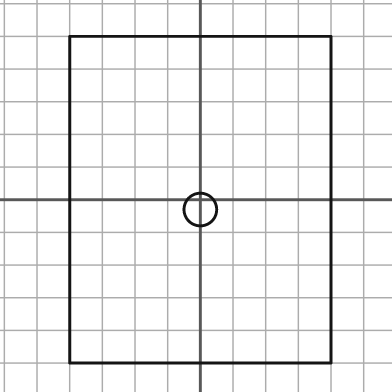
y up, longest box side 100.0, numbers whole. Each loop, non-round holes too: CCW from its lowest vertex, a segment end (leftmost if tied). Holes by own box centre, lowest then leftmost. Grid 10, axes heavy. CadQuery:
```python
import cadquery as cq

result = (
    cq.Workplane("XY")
    .moveTo(-40.0, -50.0)
    .lineTo(40.0, -50.0)
    .lineTo(40.0, 50.0)
    .lineTo(-40.0, 50.0)
    .close()
    .moveTo(0.0, -3.0)
    .circle(5.0)
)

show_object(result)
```